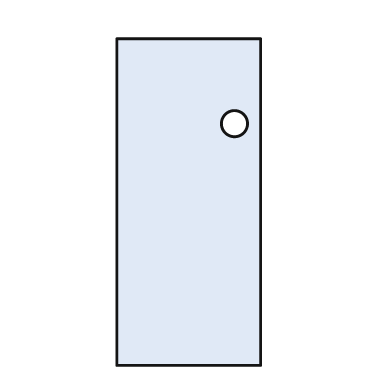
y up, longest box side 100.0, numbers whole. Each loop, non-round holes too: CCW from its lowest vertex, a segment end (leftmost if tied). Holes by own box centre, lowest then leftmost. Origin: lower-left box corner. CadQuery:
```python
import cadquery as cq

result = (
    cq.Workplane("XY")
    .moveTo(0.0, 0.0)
    .lineTo(44.0, 0.0)
    .lineTo(44.0, 100.0)
    .lineTo(0.0, 100.0)
    .close()
    .moveTo(36.0, 74.0)
    .circle(4.0)
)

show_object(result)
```